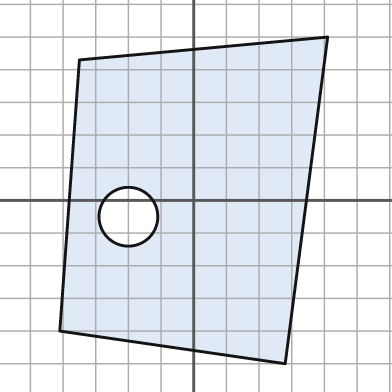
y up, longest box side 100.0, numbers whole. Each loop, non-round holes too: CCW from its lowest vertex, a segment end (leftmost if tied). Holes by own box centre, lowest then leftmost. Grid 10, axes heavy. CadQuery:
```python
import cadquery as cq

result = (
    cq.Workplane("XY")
    .moveTo(28.0, -50.0)
    .lineTo(41.0, 50.0)
    .lineTo(-35.0, 43.0)
    .lineTo(-41.0, -40.0)
    .close()
    .moveTo(-20.0, -5.0)
    .circle(9.0)
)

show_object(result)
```